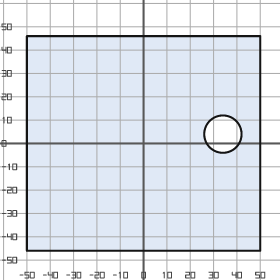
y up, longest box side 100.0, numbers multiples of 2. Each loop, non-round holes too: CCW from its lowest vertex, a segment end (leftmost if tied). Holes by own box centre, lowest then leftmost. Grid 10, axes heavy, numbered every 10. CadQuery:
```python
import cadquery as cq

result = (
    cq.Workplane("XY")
    .moveTo(-50.0, -46.0)
    .lineTo(50.0, -46.0)
    .lineTo(50.0, 46.0)
    .lineTo(-50.0, 46.0)
    .close()
    .moveTo(34.0, 4.0)
    .circle(8.0)
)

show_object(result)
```